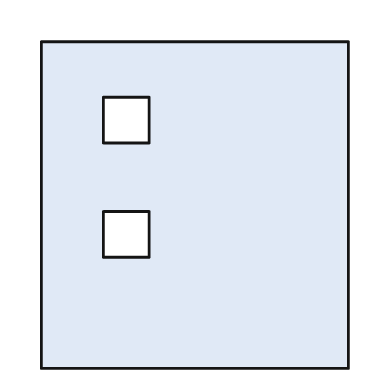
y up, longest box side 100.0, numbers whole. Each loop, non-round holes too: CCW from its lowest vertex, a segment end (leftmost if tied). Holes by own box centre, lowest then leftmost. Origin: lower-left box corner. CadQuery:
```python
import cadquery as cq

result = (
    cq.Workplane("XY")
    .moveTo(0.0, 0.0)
    .lineTo(94.0, 0.0)
    .lineTo(94.0, 100.0)
    .lineTo(0.0, 100.0)
    .close()
    .moveTo(19.0, 34.0)
    .lineTo(33.0, 34.0)
    .lineTo(33.0, 48.0)
    .lineTo(19.0, 48.0)
    .close()
    .moveTo(19.0, 69.0)
    .lineTo(33.0, 69.0)
    .lineTo(33.0, 83.0)
    .lineTo(19.0, 83.0)
    .close()
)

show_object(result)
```